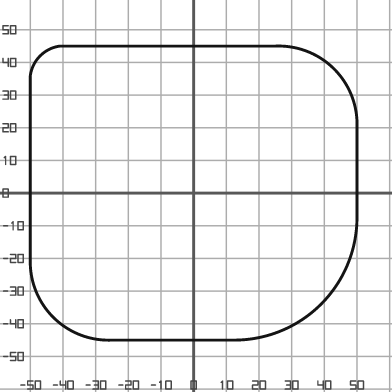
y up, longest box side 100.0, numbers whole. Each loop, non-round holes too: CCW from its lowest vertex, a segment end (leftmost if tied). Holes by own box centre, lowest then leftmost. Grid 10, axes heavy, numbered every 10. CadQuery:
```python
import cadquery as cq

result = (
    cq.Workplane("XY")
    .moveTo(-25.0, -45.0)
    .lineTo(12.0, -45.0)
    .threePointArc((39.0, -34.0), (50.0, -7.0))
    .lineTo(50.0, 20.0)
    .threePointArc((43.0, 38.0), (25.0, 45.0))
    .lineTo(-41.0, 45.0)
    .threePointArc((-47.0, 42.0), (-50.0, 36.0))
    .lineTo(-50.0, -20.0)
    .threePointArc((-43.0, -38.0), (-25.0, -45.0))
    .close()
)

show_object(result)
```